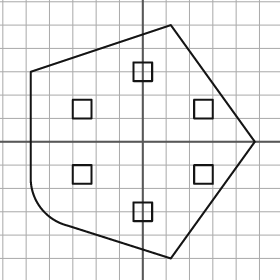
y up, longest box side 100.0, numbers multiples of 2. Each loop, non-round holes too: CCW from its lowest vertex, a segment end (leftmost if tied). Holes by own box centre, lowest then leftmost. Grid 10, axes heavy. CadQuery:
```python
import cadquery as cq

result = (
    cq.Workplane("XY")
    .moveTo(12.0, -50.0)
    .lineTo(48.0, 0.0)
    .lineTo(12.0, 50.0)
    .lineTo(-48.0, 30.0)
    .lineTo(-48.0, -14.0)
    .threePointArc((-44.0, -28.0), (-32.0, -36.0))
    .close()
    .moveTo(-4.0, -34.0)
    .lineTo(4.0, -34.0)
    .lineTo(4.0, -26.0)
    .lineTo(-4.0, -26.0)
    .close()
    .moveTo(-30.0, -18.0)
    .lineTo(-22.0, -18.0)
    .lineTo(-22.0, -10.0)
    .lineTo(-30.0, -10.0)
    .close()
    .moveTo(22.0, -18.0)
    .lineTo(30.0, -18.0)
    .lineTo(30.0, -10.0)
    .lineTo(22.0, -10.0)
    .close()
    .moveTo(-30.0, 10.0)
    .lineTo(-22.0, 10.0)
    .lineTo(-22.0, 18.0)
    .lineTo(-30.0, 18.0)
    .close()
    .moveTo(22.0, 10.0)
    .lineTo(30.0, 10.0)
    .lineTo(30.0, 18.0)
    .lineTo(22.0, 18.0)
    .close()
    .moveTo(-4.0, 26.0)
    .lineTo(4.0, 26.0)
    .lineTo(4.0, 34.0)
    .lineTo(-4.0, 34.0)
    .close()
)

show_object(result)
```